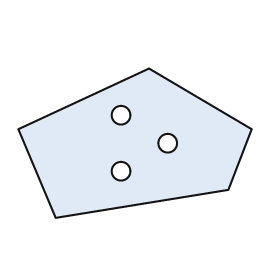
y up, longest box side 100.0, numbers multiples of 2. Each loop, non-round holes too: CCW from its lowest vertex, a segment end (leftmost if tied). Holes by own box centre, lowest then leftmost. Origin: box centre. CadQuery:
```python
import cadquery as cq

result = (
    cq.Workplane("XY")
    .moveTo(-34.0, -32.0)
    .lineTo(40.0, -20.0)
    .lineTo(50.0, 6.0)
    .lineTo(6.0, 32.0)
    .lineTo(-50.0, 6.0)
    .close()
    .moveTo(-6.0, -12.0)
    .circle(4.0)
    .moveTo(14.0, 0.0)
    .circle(4.0)
    .moveTo(-6.0, 12.0)
    .circle(4.0)
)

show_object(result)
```